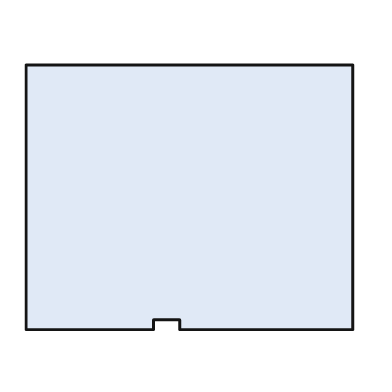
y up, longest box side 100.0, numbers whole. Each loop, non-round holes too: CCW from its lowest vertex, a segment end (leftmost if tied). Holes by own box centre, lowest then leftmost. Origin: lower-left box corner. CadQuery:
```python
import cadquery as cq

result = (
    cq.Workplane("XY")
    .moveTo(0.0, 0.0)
    .lineTo(39.0, 0.0)
    .lineTo(39.0, 3.0)
    .lineTo(47.0, 3.0)
    .lineTo(47.0, 0.0)
    .lineTo(100.0, 0.0)
    .lineTo(100.0, 81.0)
    .lineTo(0.0, 81.0)
    .close()
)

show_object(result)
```